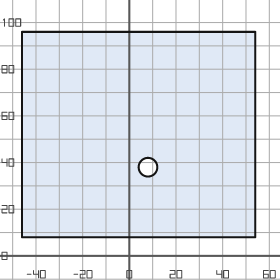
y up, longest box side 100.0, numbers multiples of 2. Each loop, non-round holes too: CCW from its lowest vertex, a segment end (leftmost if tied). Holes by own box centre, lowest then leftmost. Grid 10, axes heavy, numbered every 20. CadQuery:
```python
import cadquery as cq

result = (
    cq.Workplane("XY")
    .moveTo(-46.0, 8.0)
    .lineTo(54.0, 8.0)
    .lineTo(54.0, 96.0)
    .lineTo(-46.0, 96.0)
    .close()
    .moveTo(8.0, 38.0)
    .circle(4.0)
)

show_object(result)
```